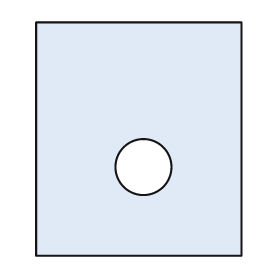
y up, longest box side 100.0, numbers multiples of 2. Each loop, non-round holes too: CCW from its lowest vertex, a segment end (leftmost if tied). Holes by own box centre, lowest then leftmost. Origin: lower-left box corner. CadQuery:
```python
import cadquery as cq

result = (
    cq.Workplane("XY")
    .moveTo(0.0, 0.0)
    .lineTo(88.0, 0.0)
    .lineTo(88.0, 100.0)
    .lineTo(0.0, 100.0)
    .close()
    .moveTo(46.0, 38.0)
    .circle(12.0)
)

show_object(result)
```